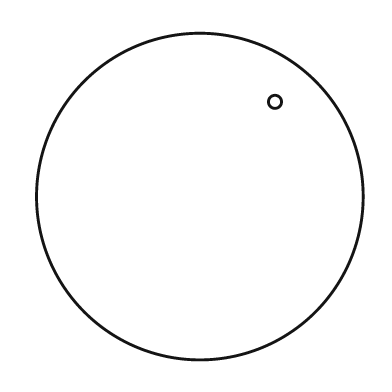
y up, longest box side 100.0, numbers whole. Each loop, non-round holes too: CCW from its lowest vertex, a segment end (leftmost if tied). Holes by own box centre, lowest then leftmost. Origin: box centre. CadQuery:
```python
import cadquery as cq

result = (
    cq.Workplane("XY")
    .moveTo(0.0, 0.0)
    .circle(50.0)
    .moveTo(23.0, 29.0)
    .circle(2.0)
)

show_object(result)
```